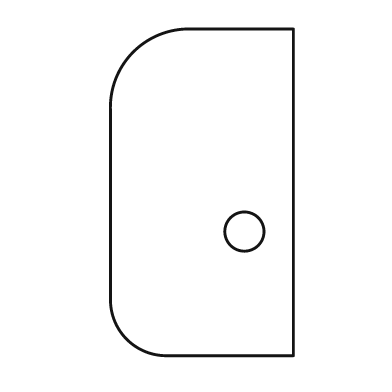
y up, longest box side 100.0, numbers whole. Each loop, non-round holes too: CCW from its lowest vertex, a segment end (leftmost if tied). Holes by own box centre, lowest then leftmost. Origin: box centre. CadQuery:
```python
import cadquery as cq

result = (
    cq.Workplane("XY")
    .moveTo(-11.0, -50.0)
    .lineTo(28.0, -50.0)
    .lineTo(28.0, 50.0)
    .lineTo(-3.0, 50.0)
    .threePointArc((-21.0, 43.0), (-28.0, 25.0))
    .lineTo(-28.0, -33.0)
    .threePointArc((-23.0, -45.0), (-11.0, -50.0))
    .close()
    .moveTo(13.0, -12.0)
    .circle(6.0)
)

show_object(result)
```